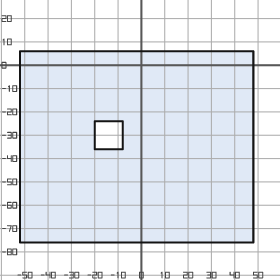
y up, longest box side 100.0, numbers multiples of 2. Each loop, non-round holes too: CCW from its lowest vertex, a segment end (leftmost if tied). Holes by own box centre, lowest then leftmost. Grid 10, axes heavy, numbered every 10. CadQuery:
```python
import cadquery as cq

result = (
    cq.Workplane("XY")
    .moveTo(-52.0, -76.0)
    .lineTo(48.0, -76.0)
    .lineTo(48.0, 6.0)
    .lineTo(-52.0, 6.0)
    .close()
    .moveTo(-20.0, -36.0)
    .lineTo(-8.0, -36.0)
    .lineTo(-8.0, -24.0)
    .lineTo(-20.0, -24.0)
    .close()
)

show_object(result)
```